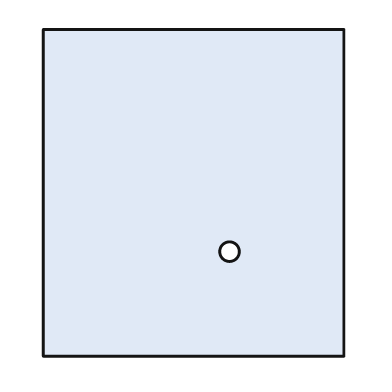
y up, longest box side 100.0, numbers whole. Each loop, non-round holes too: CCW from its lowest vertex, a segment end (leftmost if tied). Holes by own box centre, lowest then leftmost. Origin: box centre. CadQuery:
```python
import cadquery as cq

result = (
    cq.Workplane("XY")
    .moveTo(-46.0, -50.0)
    .lineTo(46.0, -50.0)
    .lineTo(46.0, 50.0)
    .lineTo(-46.0, 50.0)
    .close()
    .moveTo(11.0, -18.0)
    .circle(3.0)
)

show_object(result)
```